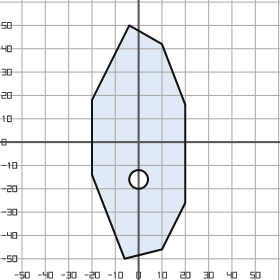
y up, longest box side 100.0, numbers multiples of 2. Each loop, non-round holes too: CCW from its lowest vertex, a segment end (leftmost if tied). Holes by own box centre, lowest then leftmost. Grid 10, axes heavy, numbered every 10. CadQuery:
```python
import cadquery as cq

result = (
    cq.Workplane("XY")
    .moveTo(-6.0, -50.0)
    .lineTo(10.0, -46.0)
    .lineTo(20.0, -26.0)
    .lineTo(20.0, 16.0)
    .lineTo(10.0, 42.0)
    .lineTo(-4.0, 50.0)
    .lineTo(-20.0, 18.0)
    .lineTo(-20.0, -14.0)
    .close()
    .moveTo(0.0, -16.0)
    .circle(4.0)
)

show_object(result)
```